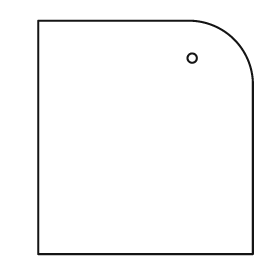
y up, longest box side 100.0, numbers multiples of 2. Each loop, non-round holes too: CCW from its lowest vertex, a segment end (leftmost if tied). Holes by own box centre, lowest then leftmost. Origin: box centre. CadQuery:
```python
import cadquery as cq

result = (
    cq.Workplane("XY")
    .moveTo(-46.0, -50.0)
    .lineTo(46.0, -50.0)
    .lineTo(46.0, 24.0)
    .threePointArc((38.0, 42.0), (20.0, 50.0))
    .lineTo(-46.0, 50.0)
    .close()
    .moveTo(20.0, 34.0)
    .circle(2.0)
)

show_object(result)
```